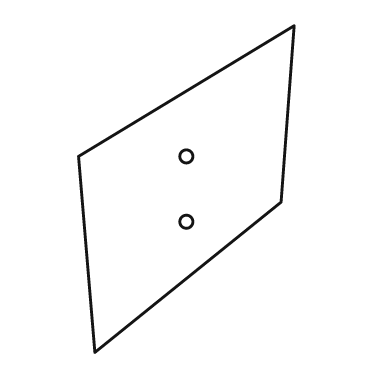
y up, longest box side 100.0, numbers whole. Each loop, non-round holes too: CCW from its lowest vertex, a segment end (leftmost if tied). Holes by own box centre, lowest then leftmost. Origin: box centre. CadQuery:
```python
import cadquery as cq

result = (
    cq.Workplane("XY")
    .moveTo(-28.0, -50.0)
    .lineTo(29.0, -4.0)
    .lineTo(33.0, 50.0)
    .lineTo(-33.0, 10.0)
    .close()
    .moveTo(0.0, -10.0)
    .circle(2.0)
    .moveTo(0.0, 10.0)
    .circle(2.0)
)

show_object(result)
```